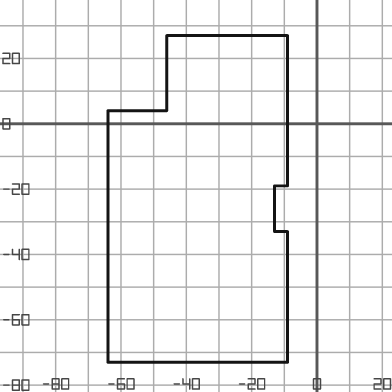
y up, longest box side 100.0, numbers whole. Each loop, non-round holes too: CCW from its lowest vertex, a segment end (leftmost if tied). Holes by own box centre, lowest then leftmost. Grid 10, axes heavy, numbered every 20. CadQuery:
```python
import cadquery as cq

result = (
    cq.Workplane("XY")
    .moveTo(-64.0, -73.0)
    .lineTo(-9.0, -73.0)
    .lineTo(-9.0, -33.0)
    .lineTo(-13.0, -33.0)
    .lineTo(-13.0, -19.0)
    .lineTo(-9.0, -19.0)
    .lineTo(-9.0, 27.0)
    .lineTo(-46.0, 27.0)
    .lineTo(-46.0, 4.0)
    .lineTo(-64.0, 4.0)
    .close()
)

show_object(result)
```